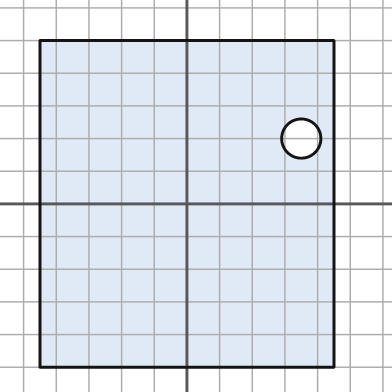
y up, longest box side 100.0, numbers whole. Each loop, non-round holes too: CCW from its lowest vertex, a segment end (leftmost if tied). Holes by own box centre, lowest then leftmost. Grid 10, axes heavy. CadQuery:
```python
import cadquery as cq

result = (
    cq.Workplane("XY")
    .moveTo(-45.0, -50.0)
    .lineTo(45.0, -50.0)
    .lineTo(45.0, 50.0)
    .lineTo(-45.0, 50.0)
    .close()
    .moveTo(35.0, 20.0)
    .circle(6.0)
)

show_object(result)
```